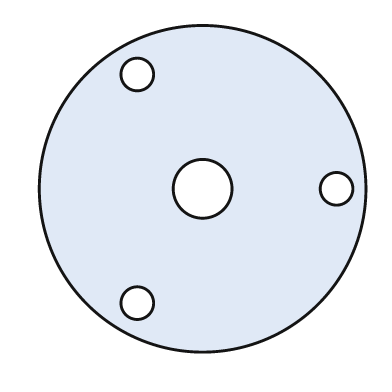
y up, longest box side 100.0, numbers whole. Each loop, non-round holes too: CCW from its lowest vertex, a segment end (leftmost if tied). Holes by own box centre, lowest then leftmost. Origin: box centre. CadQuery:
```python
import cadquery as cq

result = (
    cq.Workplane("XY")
    .moveTo(0.0, 0.0)
    .circle(50.0)
    .moveTo(-20.0, -35.0)
    .circle(5.0)
    .moveTo(0.0, 0.0)
    .circle(9.0)
    .moveTo(41.0, 0.0)
    .circle(5.0)
    .moveTo(-20.0, 35.0)
    .circle(5.0)
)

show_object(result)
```